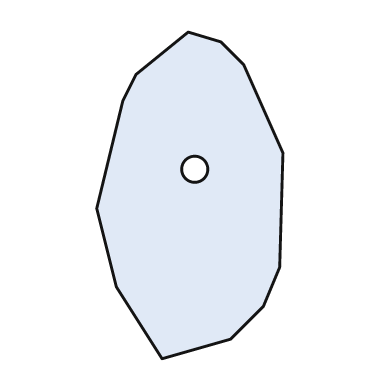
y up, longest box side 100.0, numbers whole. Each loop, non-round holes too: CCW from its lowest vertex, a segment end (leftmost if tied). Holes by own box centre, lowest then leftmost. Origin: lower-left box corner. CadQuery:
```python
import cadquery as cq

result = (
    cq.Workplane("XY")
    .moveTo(20.0, 0.0)
    .lineTo(41.0, 6.0)
    .lineTo(51.0, 16.0)
    .lineTo(56.0, 28.0)
    .lineTo(57.0, 63.0)
    .lineTo(45.0, 90.0)
    .lineTo(38.0, 97.0)
    .lineTo(28.0, 100.0)
    .lineTo(12.0, 87.0)
    .lineTo(8.0, 79.0)
    .lineTo(0.0, 46.0)
    .lineTo(6.0, 22.0)
    .close()
    .moveTo(30.0, 58.0)
    .circle(4.0)
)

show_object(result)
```